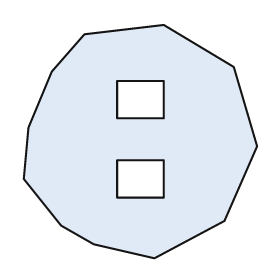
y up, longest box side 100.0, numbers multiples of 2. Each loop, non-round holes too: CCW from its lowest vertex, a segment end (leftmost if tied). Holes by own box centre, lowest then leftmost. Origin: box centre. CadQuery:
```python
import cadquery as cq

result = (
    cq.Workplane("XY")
    .moveTo(6.0, -50.0)
    .lineTo(36.0, -34.0)
    .lineTo(50.0, -2.0)
    .lineTo(40.0, 32.0)
    .lineTo(10.0, 50.0)
    .lineTo(-24.0, 46.0)
    .lineTo(-38.0, 30.0)
    .lineTo(-48.0, 6.0)
    .lineTo(-50.0, -16.0)
    .lineTo(-34.0, -36.0)
    .lineTo(-20.0, -44.0)
    .close()
    .moveTo(-10.0, -24.0)
    .lineTo(10.0, -24.0)
    .lineTo(10.0, -8.0)
    .lineTo(-10.0, -8.0)
    .close()
    .moveTo(-10.0, 10.0)
    .lineTo(10.0, 10.0)
    .lineTo(10.0, 26.0)
    .lineTo(-10.0, 26.0)
    .close()
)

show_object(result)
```